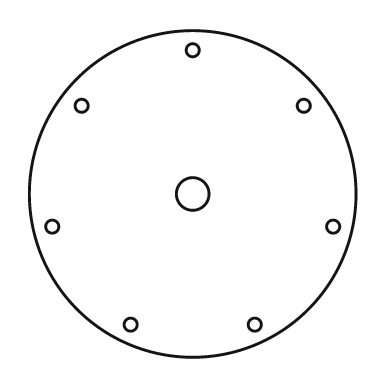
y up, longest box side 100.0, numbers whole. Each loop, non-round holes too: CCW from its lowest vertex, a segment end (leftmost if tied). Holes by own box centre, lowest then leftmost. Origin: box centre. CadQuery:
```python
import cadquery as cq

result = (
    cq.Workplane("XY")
    .moveTo(0.0, 0.0)
    .circle(50.0)
    .moveTo(-19.0, -40.0)
    .circle(2.0)
    .moveTo(19.0, -40.0)
    .circle(2.0)
    .moveTo(-43.0, -10.0)
    .circle(2.0)
    .moveTo(43.0, -10.0)
    .circle(2.0)
    .moveTo(0.0, 0.0)
    .circle(5.0)
    .moveTo(-34.0, 27.0)
    .circle(2.0)
    .moveTo(34.0, 27.0)
    .circle(2.0)
    .moveTo(0.0, 44.0)
    .circle(2.0)
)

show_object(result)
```